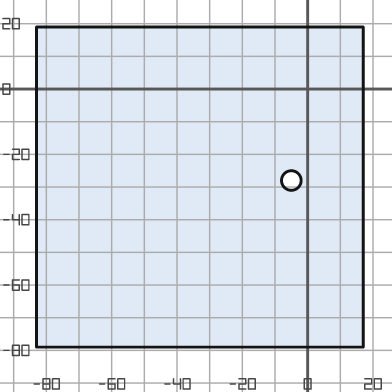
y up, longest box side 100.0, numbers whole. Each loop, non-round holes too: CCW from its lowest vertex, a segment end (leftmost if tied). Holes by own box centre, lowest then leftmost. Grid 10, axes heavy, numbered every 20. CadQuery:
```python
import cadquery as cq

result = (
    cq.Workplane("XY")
    .moveTo(-83.0, -79.0)
    .lineTo(17.0, -79.0)
    .lineTo(17.0, 19.0)
    .lineTo(-83.0, 19.0)
    .close()
    .moveTo(-5.0, -28.0)
    .circle(3.0)
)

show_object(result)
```